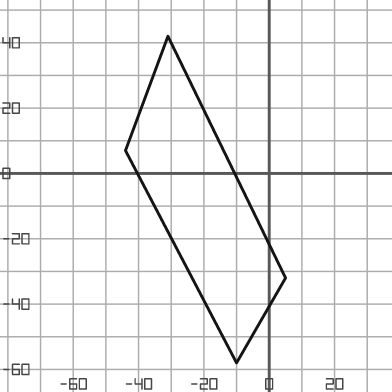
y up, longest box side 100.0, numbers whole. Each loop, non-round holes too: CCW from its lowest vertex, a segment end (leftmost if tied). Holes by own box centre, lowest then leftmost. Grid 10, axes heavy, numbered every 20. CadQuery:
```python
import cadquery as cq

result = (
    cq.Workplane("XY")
    .moveTo(-10.0, -58.0)
    .lineTo(5.0, -32.0)
    .lineTo(-31.0, 42.0)
    .lineTo(-44.0, 7.0)
    .close()
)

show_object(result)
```